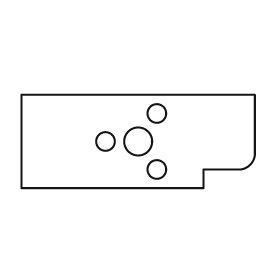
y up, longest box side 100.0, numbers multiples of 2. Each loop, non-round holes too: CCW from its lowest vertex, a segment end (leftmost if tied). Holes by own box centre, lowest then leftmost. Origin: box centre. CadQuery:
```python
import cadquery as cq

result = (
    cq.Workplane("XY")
    .moveTo(-50.0, -20.0)
    .lineTo(28.0, -20.0)
    .lineTo(28.0, -12.0)
    .lineTo(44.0, -12.0)
    .threePointArc((48.0, -10.0), (50.0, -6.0))
    .lineTo(50.0, 20.0)
    .lineTo(-50.0, 20.0)
    .close()
    .moveTo(8.0, -12.0)
    .circle(4.0)
    .moveTo(-14.0, 0.0)
    .circle(4.0)
    .moveTo(0.0, 0.0)
    .circle(6.0)
    .moveTo(8.0, 12.0)
    .circle(4.0)
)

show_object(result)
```